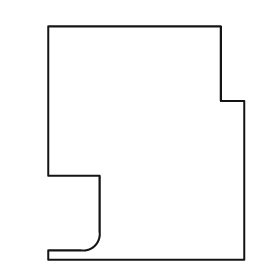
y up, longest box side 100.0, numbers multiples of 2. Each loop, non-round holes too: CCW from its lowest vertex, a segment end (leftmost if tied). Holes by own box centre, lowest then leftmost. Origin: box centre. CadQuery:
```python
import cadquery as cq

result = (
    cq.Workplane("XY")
    .moveTo(-42.0, -50.0)
    .lineTo(42.0, -50.0)
    .lineTo(42.0, 18.0)
    .lineTo(32.0, 18.0)
    .lineTo(32.0, 50.0)
    .lineTo(-42.0, 50.0)
    .lineTo(-42.0, -14.0)
    .lineTo(-20.0, -14.0)
    .lineTo(-20.0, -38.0)
    .threePointArc((-22.0, -44.0), (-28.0, -46.0))
    .lineTo(-42.0, -46.0)
    .close()
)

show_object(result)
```